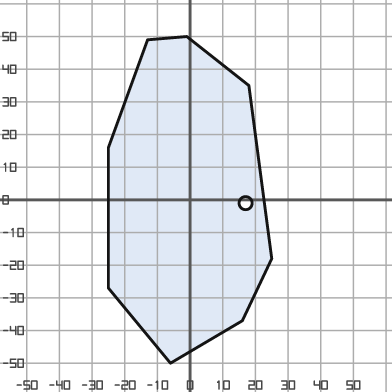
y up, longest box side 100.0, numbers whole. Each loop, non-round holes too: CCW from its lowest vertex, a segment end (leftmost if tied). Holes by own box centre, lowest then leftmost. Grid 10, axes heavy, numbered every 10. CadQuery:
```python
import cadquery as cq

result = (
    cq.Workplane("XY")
    .moveTo(-6.0, -50.0)
    .lineTo(16.0, -37.0)
    .lineTo(25.0, -18.0)
    .lineTo(18.0, 35.0)
    .lineTo(-1.0, 50.0)
    .lineTo(-13.0, 49.0)
    .lineTo(-25.0, 16.0)
    .lineTo(-25.0, -27.0)
    .close()
    .moveTo(17.0, -1.0)
    .circle(2.0)
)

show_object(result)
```